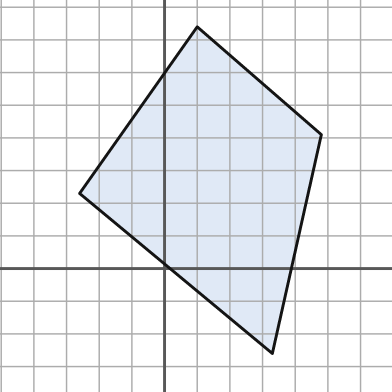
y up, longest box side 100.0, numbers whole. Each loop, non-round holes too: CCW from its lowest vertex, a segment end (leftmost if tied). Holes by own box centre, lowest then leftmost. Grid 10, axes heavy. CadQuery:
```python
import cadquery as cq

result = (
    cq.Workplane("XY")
    .moveTo(33.0, -26.0)
    .lineTo(48.0, 41.0)
    .lineTo(10.0, 74.0)
    .lineTo(-26.0, 23.0)
    .close()
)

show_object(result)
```